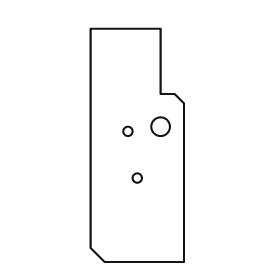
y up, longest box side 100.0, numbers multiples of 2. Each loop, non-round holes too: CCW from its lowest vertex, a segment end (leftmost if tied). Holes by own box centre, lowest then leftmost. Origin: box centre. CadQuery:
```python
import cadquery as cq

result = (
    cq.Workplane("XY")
    .moveTo(-14.0, -50.0)
    .lineTo(20.0, -50.0)
    .lineTo(20.0, 18.0)
    .lineTo(16.0, 22.0)
    .lineTo(10.0, 22.0)
    .lineTo(10.0, 50.0)
    .lineTo(-20.0, 50.0)
    .lineTo(-20.0, -44.0)
    .close()
    .moveTo(0.0, -14.0)
    .circle(2.0)
    .moveTo(-4.0, 6.0)
    .circle(2.0)
    .moveTo(10.0, 8.0)
    .circle(4.0)
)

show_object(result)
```